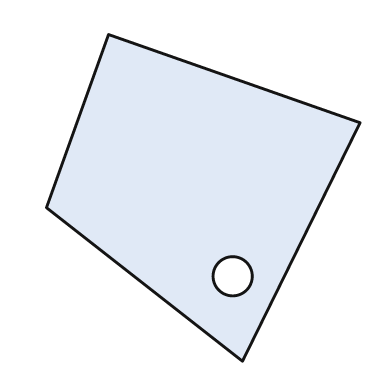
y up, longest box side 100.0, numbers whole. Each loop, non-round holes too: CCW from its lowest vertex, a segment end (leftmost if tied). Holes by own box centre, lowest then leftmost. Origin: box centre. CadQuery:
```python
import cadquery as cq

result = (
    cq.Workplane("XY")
    .moveTo(12.0, -50.0)
    .lineTo(48.0, 23.0)
    .lineTo(-29.0, 50.0)
    .lineTo(-48.0, -3.0)
    .close()
    .moveTo(9.0, -24.0)
    .circle(6.0)
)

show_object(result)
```